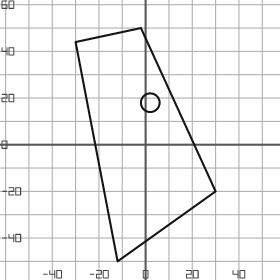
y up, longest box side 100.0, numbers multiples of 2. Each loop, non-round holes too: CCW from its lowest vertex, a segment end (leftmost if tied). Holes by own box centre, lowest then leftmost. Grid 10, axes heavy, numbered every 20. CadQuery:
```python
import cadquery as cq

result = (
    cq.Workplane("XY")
    .moveTo(-12.0, -50.0)
    .lineTo(30.0, -20.0)
    .lineTo(-2.0, 50.0)
    .lineTo(-30.0, 44.0)
    .close()
    .moveTo(2.0, 18.0)
    .circle(4.0)
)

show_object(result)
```